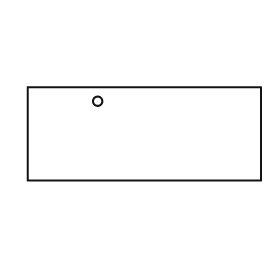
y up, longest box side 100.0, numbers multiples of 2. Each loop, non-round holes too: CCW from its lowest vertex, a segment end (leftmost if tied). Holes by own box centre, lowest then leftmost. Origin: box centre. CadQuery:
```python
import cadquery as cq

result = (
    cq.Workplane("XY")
    .moveTo(-50.0, -20.0)
    .lineTo(50.0, -20.0)
    .lineTo(50.0, 20.0)
    .lineTo(-50.0, 20.0)
    .close()
    .moveTo(-20.0, 14.0)
    .circle(2.0)
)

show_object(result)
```